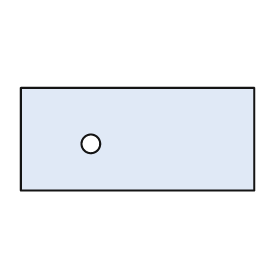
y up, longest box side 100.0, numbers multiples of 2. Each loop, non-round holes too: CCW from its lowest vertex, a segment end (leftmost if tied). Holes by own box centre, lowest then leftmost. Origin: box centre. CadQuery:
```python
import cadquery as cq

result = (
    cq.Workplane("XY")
    .moveTo(-50.0, -22.0)
    .lineTo(50.0, -22.0)
    .lineTo(50.0, 22.0)
    .lineTo(-50.0, 22.0)
    .close()
    .moveTo(-20.0, -2.0)
    .circle(4.0)
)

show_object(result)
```